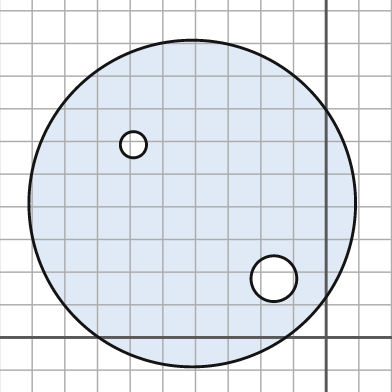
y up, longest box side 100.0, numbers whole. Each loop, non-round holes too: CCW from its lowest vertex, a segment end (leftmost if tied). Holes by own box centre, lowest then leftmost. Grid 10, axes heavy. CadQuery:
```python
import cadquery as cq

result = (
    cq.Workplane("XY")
    .moveTo(-41.0, 41.0)
    .circle(50.0)
    .moveTo(-16.0, 18.0)
    .circle(7.0)
    .moveTo(-59.0, 59.0)
    .circle(4.0)
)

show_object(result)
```